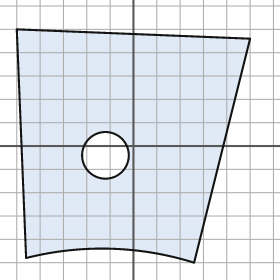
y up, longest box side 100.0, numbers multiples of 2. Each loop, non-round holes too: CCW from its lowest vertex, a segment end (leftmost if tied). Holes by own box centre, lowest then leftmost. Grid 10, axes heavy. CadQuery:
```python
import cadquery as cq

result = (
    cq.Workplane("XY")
    .moveTo(26.0, -50.0)
    .lineTo(50.0, 46.0)
    .lineTo(-50.0, 50.0)
    .lineTo(-46.0, -48.0)
    .threePointArc((-10.0, -44.0), (26.0, -50.0))
    .close()
    .moveTo(-12.0, -4.0)
    .circle(10.0)
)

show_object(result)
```